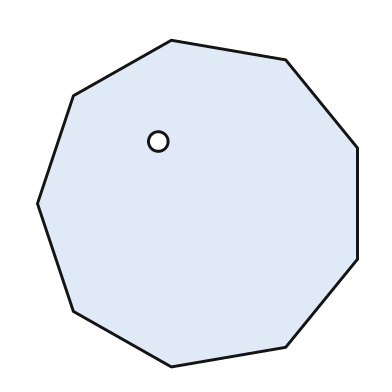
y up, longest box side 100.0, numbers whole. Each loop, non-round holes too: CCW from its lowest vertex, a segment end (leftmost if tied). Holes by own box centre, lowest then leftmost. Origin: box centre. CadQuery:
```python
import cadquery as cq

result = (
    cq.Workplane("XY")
    .moveTo(-8.0, -50.0)
    .lineTo(27.0, -44.0)
    .lineTo(49.0, -17.0)
    .lineTo(49.0, 17.0)
    .lineTo(27.0, 44.0)
    .lineTo(-8.0, 50.0)
    .lineTo(-38.0, 33.0)
    .lineTo(-49.0, 0.0)
    .lineTo(-38.0, -33.0)
    .close()
    .moveTo(-12.0, 19.0)
    .circle(3.0)
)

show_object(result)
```